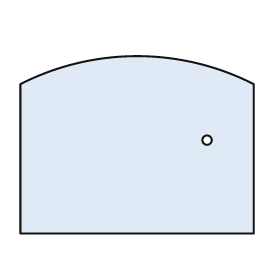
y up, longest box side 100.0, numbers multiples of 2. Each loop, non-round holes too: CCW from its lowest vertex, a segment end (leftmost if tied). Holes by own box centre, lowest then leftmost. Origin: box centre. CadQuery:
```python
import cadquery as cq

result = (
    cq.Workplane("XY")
    .moveTo(-50.0, -38.0)
    .lineTo(50.0, -38.0)
    .lineTo(50.0, 26.0)
    .threePointArc((0.0, 38.0), (-50.0, 26.0))
    .close()
    .moveTo(30.0, 2.0)
    .circle(2.0)
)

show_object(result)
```